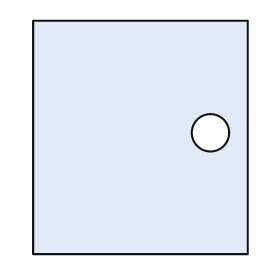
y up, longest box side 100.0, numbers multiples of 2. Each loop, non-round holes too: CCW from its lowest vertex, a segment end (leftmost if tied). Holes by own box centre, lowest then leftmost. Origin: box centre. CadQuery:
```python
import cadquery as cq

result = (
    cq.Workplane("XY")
    .moveTo(-46.0, -50.0)
    .lineTo(46.0, -50.0)
    .lineTo(46.0, 50.0)
    .lineTo(-46.0, 50.0)
    .close()
    .moveTo(30.0, 2.0)
    .circle(8.0)
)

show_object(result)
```